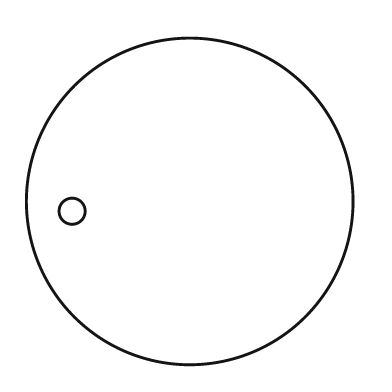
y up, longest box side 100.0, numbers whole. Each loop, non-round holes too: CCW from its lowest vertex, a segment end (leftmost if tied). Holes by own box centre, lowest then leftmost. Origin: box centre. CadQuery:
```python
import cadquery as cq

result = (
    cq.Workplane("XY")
    .moveTo(0.0, 0.0)
    .circle(50.0)
    .moveTo(-36.0, -3.0)
    .circle(4.0)
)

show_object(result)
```